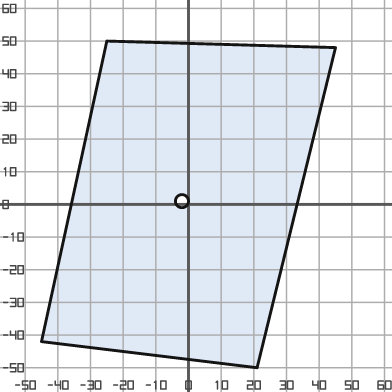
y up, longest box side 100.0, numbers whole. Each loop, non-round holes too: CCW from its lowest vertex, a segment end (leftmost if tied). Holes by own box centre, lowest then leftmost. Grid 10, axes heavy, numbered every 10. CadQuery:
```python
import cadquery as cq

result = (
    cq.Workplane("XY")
    .moveTo(21.0, -50.0)
    .lineTo(45.0, 48.0)
    .lineTo(-25.0, 50.0)
    .lineTo(-45.0, -42.0)
    .close()
    .moveTo(-2.0, 1.0)
    .circle(2.0)
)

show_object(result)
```